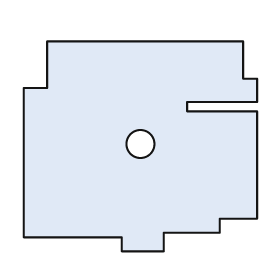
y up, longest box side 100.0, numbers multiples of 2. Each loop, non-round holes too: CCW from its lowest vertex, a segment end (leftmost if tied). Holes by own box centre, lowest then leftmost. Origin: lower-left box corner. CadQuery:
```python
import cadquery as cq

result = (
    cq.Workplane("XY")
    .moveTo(42.0, 0.0)
    .lineTo(60.0, 0.0)
    .lineTo(60.0, 8.0)
    .lineTo(84.0, 8.0)
    .lineTo(84.0, 14.0)
    .lineTo(100.0, 14.0)
    .lineTo(100.0, 60.0)
    .lineTo(70.0, 60.0)
    .lineTo(70.0, 64.0)
    .lineTo(100.0, 64.0)
    .lineTo(100.0, 74.0)
    .lineTo(94.0, 74.0)
    .lineTo(94.0, 90.0)
    .lineTo(10.0, 90.0)
    .lineTo(10.0, 70.0)
    .lineTo(0.0, 70.0)
    .lineTo(0.0, 6.0)
    .lineTo(42.0, 6.0)
    .close()
    .moveTo(50.0, 46.0)
    .circle(6.0)
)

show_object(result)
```